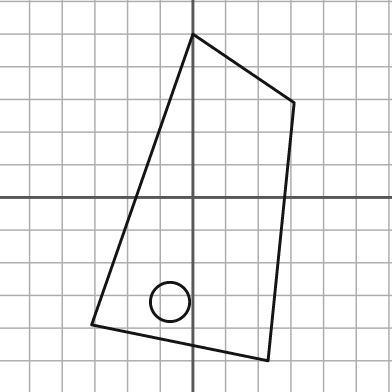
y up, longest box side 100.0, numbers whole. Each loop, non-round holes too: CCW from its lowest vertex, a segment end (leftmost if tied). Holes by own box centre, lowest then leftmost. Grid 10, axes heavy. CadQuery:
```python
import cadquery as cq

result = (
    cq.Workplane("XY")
    .moveTo(23.0, -50.0)
    .lineTo(31.0, 29.0)
    .lineTo(0.0, 50.0)
    .lineTo(-31.0, -39.0)
    .close()
    .moveTo(-7.0, -32.0)
    .circle(6.0)
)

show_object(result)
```